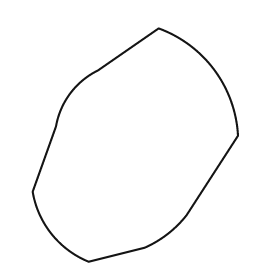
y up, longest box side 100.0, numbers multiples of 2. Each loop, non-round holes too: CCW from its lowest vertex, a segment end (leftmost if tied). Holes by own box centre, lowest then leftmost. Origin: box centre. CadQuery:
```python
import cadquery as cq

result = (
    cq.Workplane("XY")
    .moveTo(-20.0, -50.0)
    .lineTo(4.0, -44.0)
    .threePointArc((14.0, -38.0), (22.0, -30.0))
    .lineTo(44.0, 4.0)
    .threePointArc((34.0, 32.0), (10.0, 50.0))
    .lineTo(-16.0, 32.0)
    .threePointArc((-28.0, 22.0), (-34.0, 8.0))
    .lineTo(-44.0, -20.0)
    .threePointArc((-36.0, -38.0), (-20.0, -50.0))
    .close()
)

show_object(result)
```